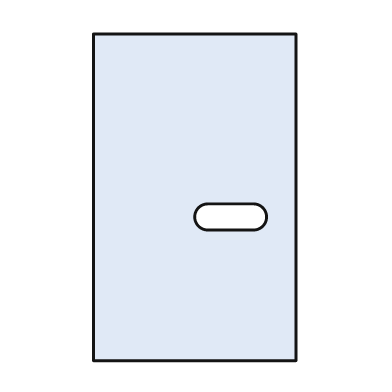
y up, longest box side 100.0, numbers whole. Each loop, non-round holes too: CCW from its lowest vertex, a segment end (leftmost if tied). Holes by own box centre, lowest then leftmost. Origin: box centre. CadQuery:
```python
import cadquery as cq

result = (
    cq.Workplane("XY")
    .moveTo(-31.0, -50.0)
    .lineTo(31.0, -50.0)
    .lineTo(31.0, 50.0)
    .lineTo(-31.0, 50.0)
    .close()
    .moveTo(4.0, -10.0)
    .lineTo(18.0, -10.0)
    .threePointArc((22.0, -6.0), (18.0, -2.0))
    .lineTo(4.0, -2.0)
    .threePointArc((0.0, -6.0), (4.0, -10.0))
    .close()
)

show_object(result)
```